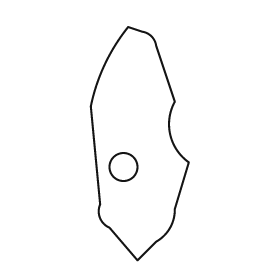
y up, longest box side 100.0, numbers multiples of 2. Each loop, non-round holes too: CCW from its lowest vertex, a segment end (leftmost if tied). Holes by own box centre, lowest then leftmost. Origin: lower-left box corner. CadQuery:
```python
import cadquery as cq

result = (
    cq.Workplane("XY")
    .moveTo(20.0, 0.0)
    .lineTo(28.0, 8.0)
    .threePointArc((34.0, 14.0), (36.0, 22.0))
    .lineTo(42.0, 42.0)
    .threePointArc((34.0, 54.0), (36.0, 68.0))
    .lineTo(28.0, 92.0)
    .threePointArc((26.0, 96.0), (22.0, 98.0))
    .lineTo(16.0, 100.0)
    .threePointArc((6.0, 84.0), (0.0, 66.0))
    .lineTo(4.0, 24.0)
    .threePointArc((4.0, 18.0), (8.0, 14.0))
    .close()
    .moveTo(14.0, 40.0)
    .circle(6.0)
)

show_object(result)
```